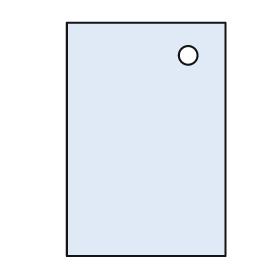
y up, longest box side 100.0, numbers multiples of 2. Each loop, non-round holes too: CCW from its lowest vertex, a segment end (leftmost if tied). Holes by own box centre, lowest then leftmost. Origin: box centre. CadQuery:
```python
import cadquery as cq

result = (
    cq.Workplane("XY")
    .moveTo(-34.0, -50.0)
    .lineTo(34.0, -50.0)
    .lineTo(34.0, 50.0)
    .lineTo(-34.0, 50.0)
    .close()
    .moveTo(18.0, 36.0)
    .circle(4.0)
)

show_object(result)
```